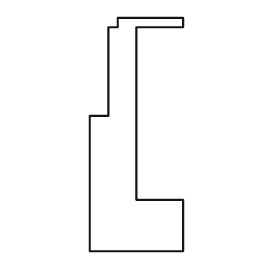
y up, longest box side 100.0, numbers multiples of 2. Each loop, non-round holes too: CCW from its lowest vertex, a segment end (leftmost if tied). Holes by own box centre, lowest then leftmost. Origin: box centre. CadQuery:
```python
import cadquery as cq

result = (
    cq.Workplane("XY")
    .moveTo(-20.0, -50.0)
    .lineTo(20.0, -50.0)
    .lineTo(20.0, -28.0)
    .lineTo(0.0, -28.0)
    .lineTo(0.0, 46.0)
    .lineTo(20.0, 46.0)
    .lineTo(20.0, 50.0)
    .lineTo(-8.0, 50.0)
    .lineTo(-8.0, 46.0)
    .lineTo(-12.0, 46.0)
    .lineTo(-12.0, 8.0)
    .lineTo(-20.0, 8.0)
    .close()
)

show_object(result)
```